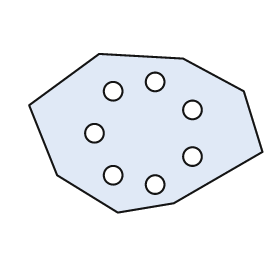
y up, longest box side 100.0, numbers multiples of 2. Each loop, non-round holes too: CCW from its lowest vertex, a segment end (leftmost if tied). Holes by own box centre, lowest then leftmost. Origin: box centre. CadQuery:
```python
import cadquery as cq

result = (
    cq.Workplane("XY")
    .moveTo(-12.0, -34.0)
    .lineTo(12.0, -30.0)
    .lineTo(50.0, -8.0)
    .lineTo(42.0, 18.0)
    .lineTo(16.0, 32.0)
    .lineTo(-20.0, 34.0)
    .lineTo(-50.0, 12.0)
    .lineTo(-38.0, -18.0)
    .close()
    .moveTo(4.0, -22.0)
    .circle(4.0)
    .moveTo(-14.0, -18.0)
    .circle(4.0)
    .moveTo(20.0, -10.0)
    .circle(4.0)
    .moveTo(-22.0, 0.0)
    .circle(4.0)
    .moveTo(20.0, 10.0)
    .circle(4.0)
    .moveTo(-14.0, 18.0)
    .circle(4.0)
    .moveTo(4.0, 22.0)
    .circle(4.0)
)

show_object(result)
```